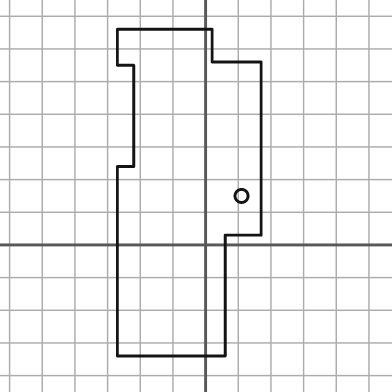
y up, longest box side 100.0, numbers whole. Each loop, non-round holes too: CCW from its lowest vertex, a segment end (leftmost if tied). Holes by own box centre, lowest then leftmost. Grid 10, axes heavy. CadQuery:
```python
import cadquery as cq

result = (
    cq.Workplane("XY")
    .moveTo(-27.0, -34.0)
    .lineTo(6.0, -34.0)
    .lineTo(6.0, 3.0)
    .lineTo(17.0, 3.0)
    .lineTo(17.0, 56.0)
    .lineTo(2.0, 56.0)
    .lineTo(2.0, 66.0)
    .lineTo(-27.0, 66.0)
    .lineTo(-27.0, 55.0)
    .lineTo(-22.0, 55.0)
    .lineTo(-22.0, 24.0)
    .lineTo(-27.0, 24.0)
    .close()
    .moveTo(11.0, 15.0)
    .circle(2.0)
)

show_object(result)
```